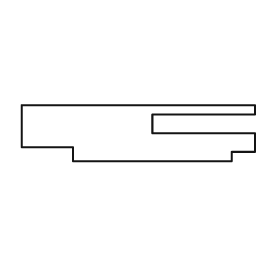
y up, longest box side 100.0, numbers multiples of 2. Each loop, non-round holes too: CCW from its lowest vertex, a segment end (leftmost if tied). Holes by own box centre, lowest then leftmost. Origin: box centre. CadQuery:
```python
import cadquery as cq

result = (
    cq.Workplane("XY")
    .moveTo(-28.0, -12.0)
    .lineTo(40.0, -12.0)
    .lineTo(40.0, -8.0)
    .lineTo(50.0, -8.0)
    .lineTo(50.0, 0.0)
    .lineTo(6.0, 0.0)
    .lineTo(6.0, 8.0)
    .lineTo(50.0, 8.0)
    .lineTo(50.0, 12.0)
    .lineTo(-50.0, 12.0)
    .lineTo(-50.0, -6.0)
    .lineTo(-28.0, -6.0)
    .close()
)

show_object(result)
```